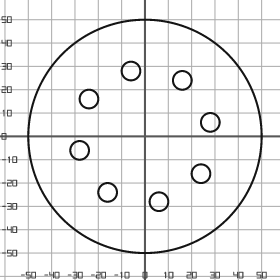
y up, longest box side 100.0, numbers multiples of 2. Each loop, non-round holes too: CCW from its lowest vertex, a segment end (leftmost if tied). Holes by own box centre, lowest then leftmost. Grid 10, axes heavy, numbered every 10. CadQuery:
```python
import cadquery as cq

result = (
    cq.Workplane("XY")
    .moveTo(0.0, 0.0)
    .circle(50.0)
    .moveTo(6.0, -28.0)
    .circle(4.0)
    .moveTo(-16.0, -24.0)
    .circle(4.0)
    .moveTo(24.0, -16.0)
    .circle(4.0)
    .moveTo(-28.0, -6.0)
    .circle(4.0)
    .moveTo(28.0, 6.0)
    .circle(4.0)
    .moveTo(-24.0, 16.0)
    .circle(4.0)
    .moveTo(16.0, 24.0)
    .circle(4.0)
    .moveTo(-6.0, 28.0)
    .circle(4.0)
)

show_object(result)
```